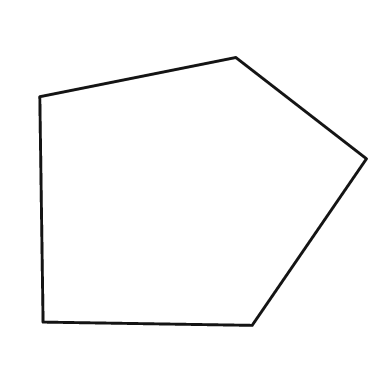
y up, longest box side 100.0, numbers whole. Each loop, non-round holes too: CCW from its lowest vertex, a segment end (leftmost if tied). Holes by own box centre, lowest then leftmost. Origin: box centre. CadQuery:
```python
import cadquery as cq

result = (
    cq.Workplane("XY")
    .moveTo(15.0, -41.0)
    .lineTo(50.0, 10.0)
    .lineTo(10.0, 41.0)
    .lineTo(-50.0, 29.0)
    .lineTo(-49.0, -40.0)
    .close()
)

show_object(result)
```